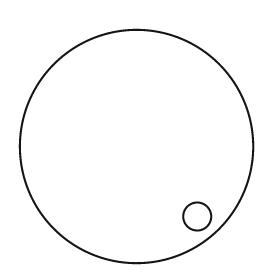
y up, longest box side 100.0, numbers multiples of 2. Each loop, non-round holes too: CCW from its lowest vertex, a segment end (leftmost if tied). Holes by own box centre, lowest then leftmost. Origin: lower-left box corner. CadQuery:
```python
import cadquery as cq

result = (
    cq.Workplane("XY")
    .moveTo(50.0, 50.0)
    .circle(50.0)
    .moveTo(76.0, 20.0)
    .circle(6.0)
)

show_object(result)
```